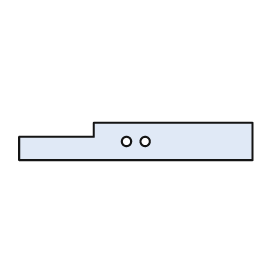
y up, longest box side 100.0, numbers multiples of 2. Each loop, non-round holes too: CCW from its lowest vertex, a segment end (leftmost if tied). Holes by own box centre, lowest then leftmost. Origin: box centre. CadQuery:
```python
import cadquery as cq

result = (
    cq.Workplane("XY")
    .moveTo(-50.0, -8.0)
    .lineTo(50.0, -8.0)
    .lineTo(50.0, 8.0)
    .lineTo(-18.0, 8.0)
    .lineTo(-18.0, 2.0)
    .lineTo(-50.0, 2.0)
    .close()
    .moveTo(-4.0, 0.0)
    .circle(2.0)
    .moveTo(4.0, 0.0)
    .circle(2.0)
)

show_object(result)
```